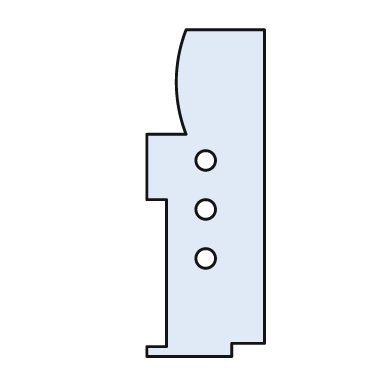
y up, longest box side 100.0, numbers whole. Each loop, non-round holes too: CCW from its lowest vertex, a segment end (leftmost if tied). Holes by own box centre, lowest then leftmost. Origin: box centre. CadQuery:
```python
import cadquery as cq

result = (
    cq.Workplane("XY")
    .moveTo(-18.0, -50.0)
    .lineTo(8.0, -50.0)
    .lineTo(8.0, -46.0)
    .lineTo(18.0, -46.0)
    .lineTo(18.0, 50.0)
    .lineTo(-6.0, 50.0)
    .threePointArc((-9.0, 34.0), (-6.0, 18.0))
    .lineTo(-18.0, 18.0)
    .lineTo(-18.0, -2.0)
    .lineTo(-12.0, -2.0)
    .lineTo(-12.0, -47.0)
    .lineTo(-18.0, -47.0)
    .close()
    .moveTo(0.0, -20.0)
    .circle(3.0)
    .moveTo(0.0, -5.0)
    .circle(3.0)
    .moveTo(0.0, 10.0)
    .circle(3.0)
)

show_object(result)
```